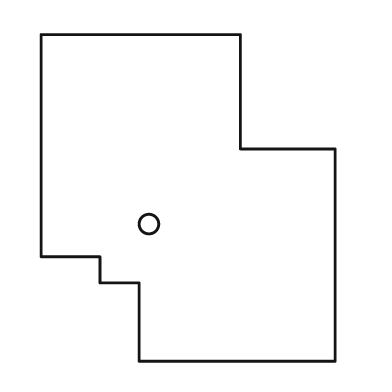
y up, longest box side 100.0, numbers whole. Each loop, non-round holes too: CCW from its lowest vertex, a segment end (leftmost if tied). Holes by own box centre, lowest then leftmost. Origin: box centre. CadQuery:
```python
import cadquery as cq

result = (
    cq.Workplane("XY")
    .moveTo(-15.0, -50.0)
    .lineTo(45.0, -50.0)
    .lineTo(45.0, 15.0)
    .lineTo(16.0, 15.0)
    .lineTo(16.0, 50.0)
    .lineTo(-45.0, 50.0)
    .lineTo(-45.0, -18.0)
    .lineTo(-27.0, -18.0)
    .lineTo(-27.0, -26.0)
    .lineTo(-15.0, -26.0)
    .close()
    .moveTo(-12.0, -8.0)
    .circle(3.0)
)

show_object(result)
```